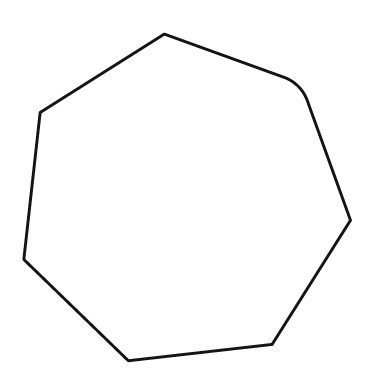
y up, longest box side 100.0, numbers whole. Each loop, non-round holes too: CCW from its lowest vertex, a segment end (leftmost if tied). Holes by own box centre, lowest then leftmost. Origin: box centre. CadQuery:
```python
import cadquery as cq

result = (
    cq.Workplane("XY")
    .moveTo(-18.0, -50.0)
    .lineTo(26.0, -45.0)
    .lineTo(50.0, -7.0)
    .lineTo(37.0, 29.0)
    .threePointArc((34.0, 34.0), (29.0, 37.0))
    .lineTo(-7.0, 50.0)
    .lineTo(-45.0, 26.0)
    .lineTo(-50.0, -19.0)
    .close()
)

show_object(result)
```